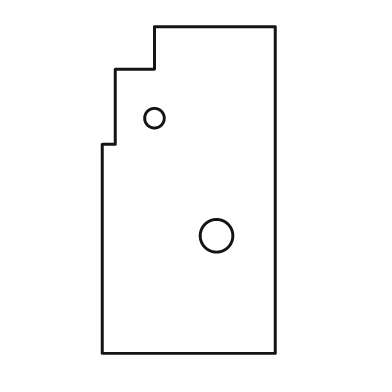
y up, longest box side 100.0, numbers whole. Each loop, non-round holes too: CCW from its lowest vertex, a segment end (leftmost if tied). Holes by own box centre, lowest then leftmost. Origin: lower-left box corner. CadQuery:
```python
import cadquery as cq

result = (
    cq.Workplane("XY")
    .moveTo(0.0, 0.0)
    .lineTo(53.0, 0.0)
    .lineTo(53.0, 100.0)
    .lineTo(16.0, 100.0)
    .lineTo(16.0, 87.0)
    .lineTo(4.0, 87.0)
    .lineTo(4.0, 64.0)
    .lineTo(0.0, 64.0)
    .close()
    .moveTo(35.0, 36.0)
    .circle(5.0)
    .moveTo(16.0, 72.0)
    .circle(3.0)
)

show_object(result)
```